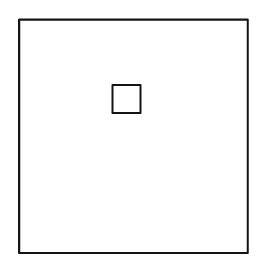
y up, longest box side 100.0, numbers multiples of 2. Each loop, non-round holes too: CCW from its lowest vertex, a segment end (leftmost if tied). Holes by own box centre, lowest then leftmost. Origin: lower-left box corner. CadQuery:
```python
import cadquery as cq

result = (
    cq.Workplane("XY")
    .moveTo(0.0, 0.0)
    .lineTo(98.0, 0.0)
    .lineTo(98.0, 100.0)
    .lineTo(0.0, 100.0)
    .close()
    .moveTo(40.0, 60.0)
    .lineTo(52.0, 60.0)
    .lineTo(52.0, 72.0)
    .lineTo(40.0, 72.0)
    .close()
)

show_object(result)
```